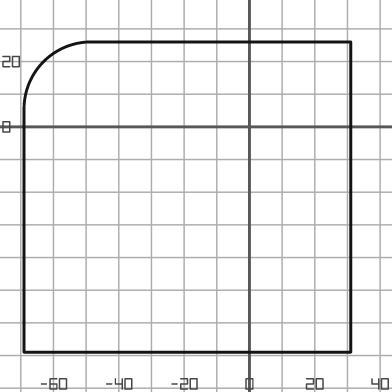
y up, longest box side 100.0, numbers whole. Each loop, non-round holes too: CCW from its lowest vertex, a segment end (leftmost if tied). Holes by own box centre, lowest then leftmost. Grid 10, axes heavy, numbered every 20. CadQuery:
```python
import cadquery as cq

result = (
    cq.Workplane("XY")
    .moveTo(-69.0, -69.0)
    .lineTo(31.0, -69.0)
    .lineTo(31.0, 26.0)
    .lineTo(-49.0, 26.0)
    .threePointArc((-63.0, 20.0), (-69.0, 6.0))
    .close()
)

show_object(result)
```